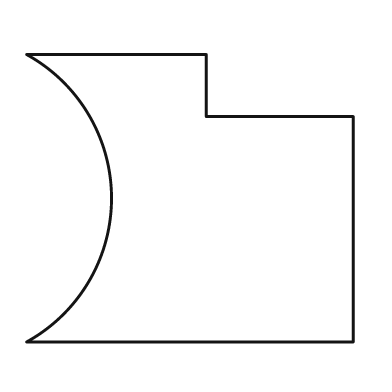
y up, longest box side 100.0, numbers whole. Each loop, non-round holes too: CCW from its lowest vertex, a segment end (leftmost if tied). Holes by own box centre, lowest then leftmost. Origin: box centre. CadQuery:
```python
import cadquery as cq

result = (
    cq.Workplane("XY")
    .moveTo(-50.0, -44.0)
    .lineTo(50.0, -44.0)
    .lineTo(50.0, 25.0)
    .lineTo(5.0, 25.0)
    .lineTo(5.0, 44.0)
    .lineTo(-50.0, 44.0)
    .threePointArc((-24.0, 0.0), (-50.0, -44.0))
    .close()
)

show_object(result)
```